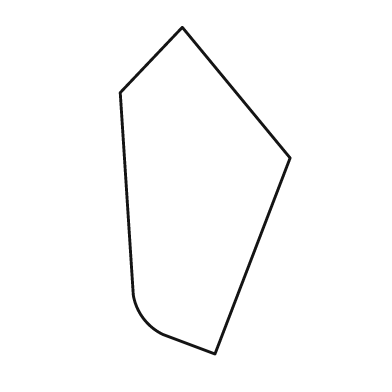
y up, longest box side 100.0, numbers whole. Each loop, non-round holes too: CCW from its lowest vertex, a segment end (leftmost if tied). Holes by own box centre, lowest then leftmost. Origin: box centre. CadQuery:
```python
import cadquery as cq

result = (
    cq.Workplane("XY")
    .moveTo(3.0, -50.0)
    .lineTo(26.0, 10.0)
    .lineTo(-7.0, 50.0)
    .lineTo(-26.0, 30.0)
    .lineTo(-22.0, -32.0)
    .threePointArc((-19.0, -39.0), (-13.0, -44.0))
    .close()
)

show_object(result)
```